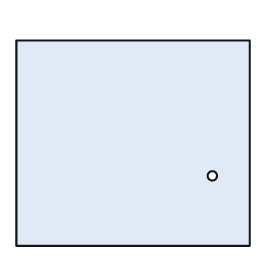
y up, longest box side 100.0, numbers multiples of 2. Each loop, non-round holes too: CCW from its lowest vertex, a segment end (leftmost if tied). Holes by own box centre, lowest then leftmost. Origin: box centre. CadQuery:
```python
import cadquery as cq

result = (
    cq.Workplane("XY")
    .moveTo(-50.0, -44.0)
    .lineTo(50.0, -44.0)
    .lineTo(50.0, 44.0)
    .lineTo(-50.0, 44.0)
    .close()
    .moveTo(34.0, -14.0)
    .circle(2.0)
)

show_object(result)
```